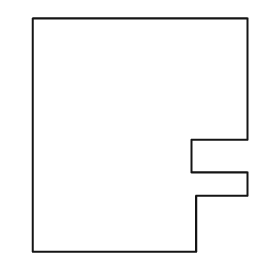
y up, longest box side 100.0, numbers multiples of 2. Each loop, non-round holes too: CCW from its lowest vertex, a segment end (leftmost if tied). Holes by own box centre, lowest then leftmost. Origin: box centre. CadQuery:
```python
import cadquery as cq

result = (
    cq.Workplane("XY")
    .moveTo(-46.0, -50.0)
    .lineTo(24.0, -50.0)
    .lineTo(24.0, -26.0)
    .lineTo(46.0, -26.0)
    .lineTo(46.0, -16.0)
    .lineTo(22.0, -16.0)
    .lineTo(22.0, -2.0)
    .lineTo(46.0, -2.0)
    .lineTo(46.0, 50.0)
    .lineTo(-46.0, 50.0)
    .close()
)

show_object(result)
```